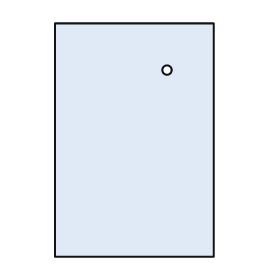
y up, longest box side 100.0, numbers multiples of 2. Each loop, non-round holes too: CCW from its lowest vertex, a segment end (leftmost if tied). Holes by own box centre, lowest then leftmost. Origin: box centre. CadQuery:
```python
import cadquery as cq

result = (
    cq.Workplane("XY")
    .moveTo(-34.0, -50.0)
    .lineTo(34.0, -50.0)
    .lineTo(34.0, 50.0)
    .lineTo(-34.0, 50.0)
    .close()
    .moveTo(14.0, 30.0)
    .circle(2.0)
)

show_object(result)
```